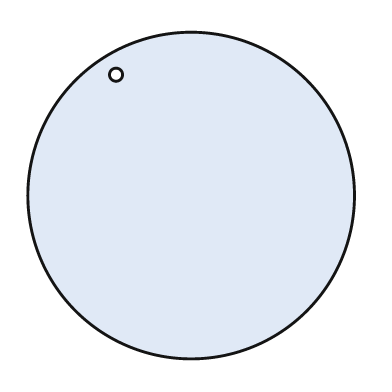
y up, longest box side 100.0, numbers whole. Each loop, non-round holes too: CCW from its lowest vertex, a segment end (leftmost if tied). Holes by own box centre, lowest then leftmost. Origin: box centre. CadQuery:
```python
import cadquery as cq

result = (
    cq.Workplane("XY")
    .moveTo(0.0, 0.0)
    .circle(50.0)
    .moveTo(-23.0, 37.0)
    .circle(2.0)
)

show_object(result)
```